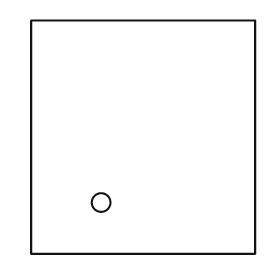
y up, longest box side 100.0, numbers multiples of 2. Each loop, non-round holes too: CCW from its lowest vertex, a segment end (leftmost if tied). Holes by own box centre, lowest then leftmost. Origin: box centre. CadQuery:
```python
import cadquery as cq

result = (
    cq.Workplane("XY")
    .moveTo(-48.0, -50.0)
    .lineTo(48.0, -50.0)
    .lineTo(48.0, 50.0)
    .lineTo(-48.0, 50.0)
    .close()
    .moveTo(-18.0, -28.0)
    .circle(4.0)
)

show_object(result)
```